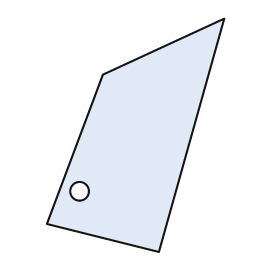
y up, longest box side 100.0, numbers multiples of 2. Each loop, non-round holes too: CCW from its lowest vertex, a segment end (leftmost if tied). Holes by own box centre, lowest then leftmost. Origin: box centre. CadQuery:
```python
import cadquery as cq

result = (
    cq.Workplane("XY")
    .moveTo(10.0, -50.0)
    .lineTo(38.0, 50.0)
    .lineTo(-14.0, 26.0)
    .lineTo(-38.0, -38.0)
    .close()
    .moveTo(-24.0, -24.0)
    .circle(4.0)
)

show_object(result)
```